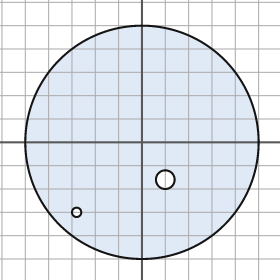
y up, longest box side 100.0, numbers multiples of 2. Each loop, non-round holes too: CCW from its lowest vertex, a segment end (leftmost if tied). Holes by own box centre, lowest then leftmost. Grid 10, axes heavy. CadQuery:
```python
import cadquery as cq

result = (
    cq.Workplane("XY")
    .moveTo(0.0, 0.0)
    .circle(50.0)
    .moveTo(-28.0, -30.0)
    .circle(2.0)
    .moveTo(10.0, -16.0)
    .circle(4.0)
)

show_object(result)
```